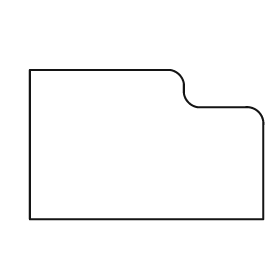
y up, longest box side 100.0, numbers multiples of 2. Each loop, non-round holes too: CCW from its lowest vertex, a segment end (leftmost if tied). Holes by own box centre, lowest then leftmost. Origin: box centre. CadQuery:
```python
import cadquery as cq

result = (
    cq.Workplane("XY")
    .moveTo(-50.0, -32.0)
    .lineTo(50.0, -32.0)
    .lineTo(50.0, 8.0)
    .threePointArc((48.0, 14.0), (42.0, 16.0))
    .lineTo(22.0, 16.0)
    .threePointArc((18.0, 18.0), (16.0, 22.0))
    .lineTo(16.0, 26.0)
    .threePointArc((14.0, 30.0), (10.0, 32.0))
    .lineTo(-50.0, 32.0)
    .close()
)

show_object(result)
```